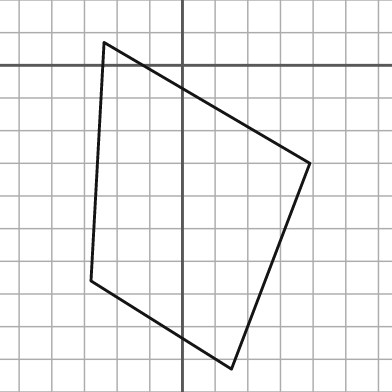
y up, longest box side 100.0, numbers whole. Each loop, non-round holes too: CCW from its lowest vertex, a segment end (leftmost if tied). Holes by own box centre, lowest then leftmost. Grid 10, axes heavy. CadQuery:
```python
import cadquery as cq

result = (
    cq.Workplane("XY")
    .moveTo(15.0, -93.0)
    .lineTo(39.0, -30.0)
    .lineTo(-24.0, 7.0)
    .lineTo(-28.0, -66.0)
    .close()
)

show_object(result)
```